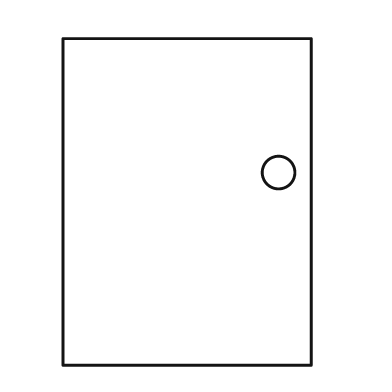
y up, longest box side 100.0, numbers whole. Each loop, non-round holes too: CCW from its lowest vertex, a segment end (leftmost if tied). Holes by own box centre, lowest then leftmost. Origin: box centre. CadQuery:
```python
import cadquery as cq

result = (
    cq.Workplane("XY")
    .moveTo(-38.0, -50.0)
    .lineTo(38.0, -50.0)
    .lineTo(38.0, 50.0)
    .lineTo(-38.0, 50.0)
    .close()
    .moveTo(28.0, 9.0)
    .circle(5.0)
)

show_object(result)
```